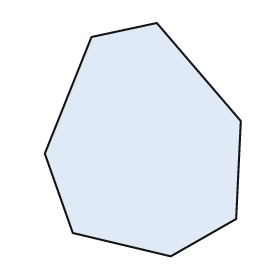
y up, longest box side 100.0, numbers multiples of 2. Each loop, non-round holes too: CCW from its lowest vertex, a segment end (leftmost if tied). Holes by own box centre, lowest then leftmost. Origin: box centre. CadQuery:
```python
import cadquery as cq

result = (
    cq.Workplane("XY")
    .moveTo(12.0, -50.0)
    .lineTo(40.0, -34.0)
    .lineTo(42.0, 8.0)
    .lineTo(6.0, 50.0)
    .lineTo(-22.0, 44.0)
    .lineTo(-42.0, -6.0)
    .lineTo(-30.0, -40.0)
    .close()
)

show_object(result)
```